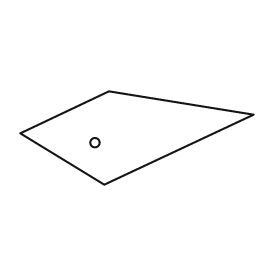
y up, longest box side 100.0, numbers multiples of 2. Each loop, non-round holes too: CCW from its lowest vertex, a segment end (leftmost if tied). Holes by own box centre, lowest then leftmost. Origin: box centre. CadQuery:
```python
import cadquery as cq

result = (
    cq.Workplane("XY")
    .moveTo(-14.0, -20.0)
    .lineTo(50.0, 10.0)
    .lineTo(-12.0, 20.0)
    .lineTo(-50.0, 2.0)
    .close()
    .moveTo(-18.0, -2.0)
    .circle(2.0)
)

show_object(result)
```